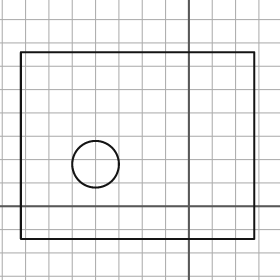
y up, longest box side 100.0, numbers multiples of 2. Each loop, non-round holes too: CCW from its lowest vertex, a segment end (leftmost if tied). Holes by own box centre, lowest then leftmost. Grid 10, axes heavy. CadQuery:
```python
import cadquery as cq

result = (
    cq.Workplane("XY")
    .moveTo(-72.0, -14.0)
    .lineTo(28.0, -14.0)
    .lineTo(28.0, 66.0)
    .lineTo(-72.0, 66.0)
    .close()
    .moveTo(-40.0, 18.0)
    .circle(10.0)
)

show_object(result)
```